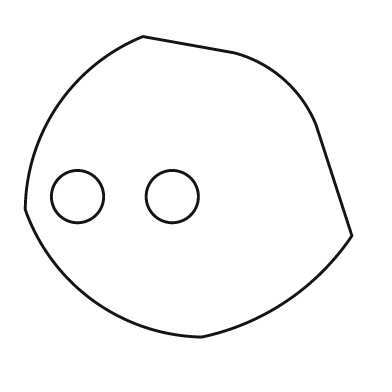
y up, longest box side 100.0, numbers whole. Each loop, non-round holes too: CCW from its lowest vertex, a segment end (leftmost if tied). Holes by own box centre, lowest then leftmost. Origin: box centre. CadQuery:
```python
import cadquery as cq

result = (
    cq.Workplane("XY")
    .moveTo(4.0, -46.0)
    .threePointArc((30.0, -35.0), (50.0, -15.0))
    .lineTo(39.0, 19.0)
    .threePointArc((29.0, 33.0), (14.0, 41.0))
    .lineTo(-14.0, 46.0)
    .threePointArc((-40.0, 25.0), (-50.0, -7.0))
    .threePointArc((-29.0, -35.0), (4.0, -46.0))
    .close()
    .moveTo(-34.0, -3.0)
    .circle(8.0)
    .moveTo(-5.0, -3.0)
    .circle(8.0)
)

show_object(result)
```